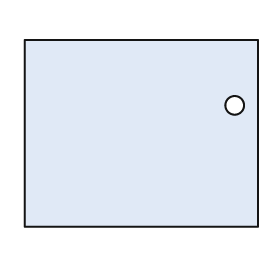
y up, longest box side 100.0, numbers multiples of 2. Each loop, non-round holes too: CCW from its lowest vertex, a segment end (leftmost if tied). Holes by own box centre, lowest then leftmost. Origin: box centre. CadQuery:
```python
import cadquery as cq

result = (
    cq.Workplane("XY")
    .moveTo(-50.0, -40.0)
    .lineTo(50.0, -40.0)
    .lineTo(50.0, 40.0)
    .lineTo(-50.0, 40.0)
    .close()
    .moveTo(40.0, 12.0)
    .circle(4.0)
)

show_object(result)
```